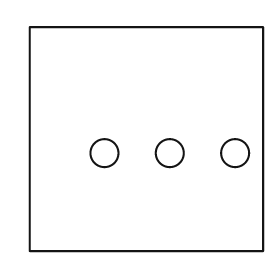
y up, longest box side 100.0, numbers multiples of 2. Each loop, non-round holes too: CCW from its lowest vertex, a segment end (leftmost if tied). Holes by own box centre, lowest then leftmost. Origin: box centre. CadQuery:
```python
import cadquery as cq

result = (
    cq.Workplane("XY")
    .moveTo(-50.0, -48.0)
    .lineTo(50.0, -48.0)
    .lineTo(50.0, 48.0)
    .lineTo(-50.0, 48.0)
    .close()
    .moveTo(-18.0, -6.0)
    .circle(6.0)
    .moveTo(10.0, -6.0)
    .circle(6.0)
    .moveTo(38.0, -6.0)
    .circle(6.0)
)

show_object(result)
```